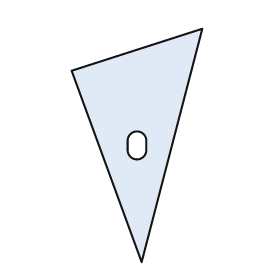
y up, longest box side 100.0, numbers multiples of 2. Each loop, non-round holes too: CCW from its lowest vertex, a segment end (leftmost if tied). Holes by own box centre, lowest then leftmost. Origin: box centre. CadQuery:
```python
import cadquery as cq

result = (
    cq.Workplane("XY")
    .moveTo(2.0, -50.0)
    .lineTo(28.0, 50.0)
    .lineTo(-28.0, 32.0)
    .close()
    .moveTo(-4.0, -2.0)
    .threePointArc((0.0, -6.0), (4.0, -2.0))
    .lineTo(4.0, 2.0)
    .threePointArc((0.0, 6.0), (-4.0, 2.0))
    .close()
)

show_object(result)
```